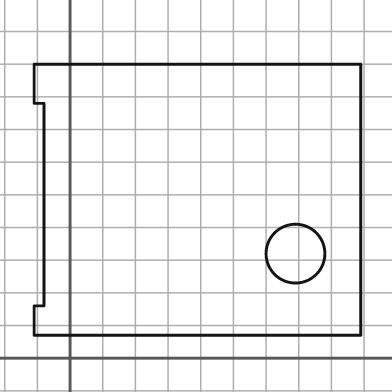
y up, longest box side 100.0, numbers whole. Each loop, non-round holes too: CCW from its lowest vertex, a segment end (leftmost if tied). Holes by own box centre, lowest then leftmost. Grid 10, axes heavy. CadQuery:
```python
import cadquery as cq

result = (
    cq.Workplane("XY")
    .moveTo(-11.0, 7.0)
    .lineTo(89.0, 7.0)
    .lineTo(89.0, 90.0)
    .lineTo(-11.0, 90.0)
    .lineTo(-11.0, 78.0)
    .lineTo(-8.0, 78.0)
    .lineTo(-8.0, 16.0)
    .lineTo(-11.0, 16.0)
    .close()
    .moveTo(69.0, 32.0)
    .circle(9.0)
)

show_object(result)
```